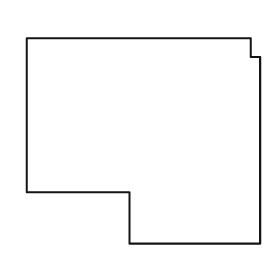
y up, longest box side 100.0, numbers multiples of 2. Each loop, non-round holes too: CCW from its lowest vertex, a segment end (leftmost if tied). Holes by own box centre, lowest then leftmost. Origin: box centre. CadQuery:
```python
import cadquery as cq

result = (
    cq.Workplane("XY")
    .moveTo(-6.0, -44.0)
    .lineTo(50.0, -44.0)
    .lineTo(50.0, 36.0)
    .lineTo(46.0, 36.0)
    .lineTo(46.0, 44.0)
    .lineTo(-50.0, 44.0)
    .lineTo(-50.0, -22.0)
    .lineTo(-6.0, -22.0)
    .close()
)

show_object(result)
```